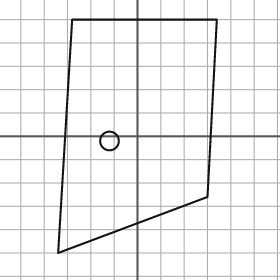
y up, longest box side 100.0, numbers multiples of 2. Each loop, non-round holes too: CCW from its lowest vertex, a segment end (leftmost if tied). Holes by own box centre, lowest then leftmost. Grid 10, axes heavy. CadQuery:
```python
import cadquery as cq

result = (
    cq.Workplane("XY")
    .moveTo(-34.0, -50.0)
    .lineTo(30.0, -26.0)
    .lineTo(34.0, 50.0)
    .lineTo(-28.0, 50.0)
    .close()
    .moveTo(-12.0, -2.0)
    .circle(4.0)
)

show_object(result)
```